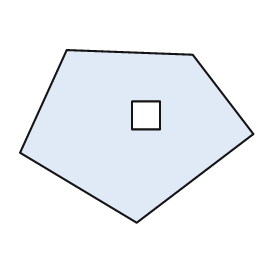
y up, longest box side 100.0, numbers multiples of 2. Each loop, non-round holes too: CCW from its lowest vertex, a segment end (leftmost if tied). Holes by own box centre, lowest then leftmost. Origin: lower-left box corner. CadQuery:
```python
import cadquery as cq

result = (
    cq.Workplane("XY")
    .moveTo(50.0, 0.0)
    .lineTo(100.0, 38.0)
    .lineTo(74.0, 72.0)
    .lineTo(20.0, 74.0)
    .lineTo(0.0, 30.0)
    .close()
    .moveTo(48.0, 40.0)
    .lineTo(60.0, 40.0)
    .lineTo(60.0, 52.0)
    .lineTo(48.0, 52.0)
    .close()
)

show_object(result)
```